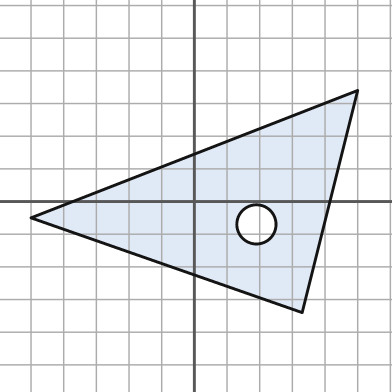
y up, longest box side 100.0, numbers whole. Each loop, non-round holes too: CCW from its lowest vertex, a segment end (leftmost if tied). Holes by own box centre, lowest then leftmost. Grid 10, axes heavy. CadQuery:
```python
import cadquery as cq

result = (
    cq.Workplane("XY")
    .moveTo(33.0, -34.0)
    .lineTo(50.0, 34.0)
    .lineTo(-50.0, -5.0)
    .close()
    .moveTo(19.0, -7.0)
    .circle(6.0)
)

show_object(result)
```